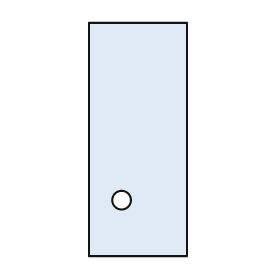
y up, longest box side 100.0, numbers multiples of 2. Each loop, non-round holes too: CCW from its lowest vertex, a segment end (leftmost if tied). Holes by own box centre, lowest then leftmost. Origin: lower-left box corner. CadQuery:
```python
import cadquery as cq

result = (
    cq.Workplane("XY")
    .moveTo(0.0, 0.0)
    .lineTo(42.0, 0.0)
    .lineTo(42.0, 100.0)
    .lineTo(0.0, 100.0)
    .close()
    .moveTo(14.0, 24.0)
    .circle(4.0)
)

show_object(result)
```